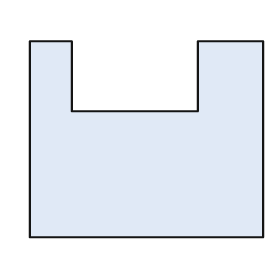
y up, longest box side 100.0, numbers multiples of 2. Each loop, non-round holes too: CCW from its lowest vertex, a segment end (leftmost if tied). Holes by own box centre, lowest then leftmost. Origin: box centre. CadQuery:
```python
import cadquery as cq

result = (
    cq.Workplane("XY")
    .moveTo(-50.0, -42.0)
    .lineTo(50.0, -42.0)
    .lineTo(50.0, 42.0)
    .lineTo(22.0, 42.0)
    .lineTo(22.0, 12.0)
    .lineTo(-32.0, 12.0)
    .lineTo(-32.0, 42.0)
    .lineTo(-50.0, 42.0)
    .close()
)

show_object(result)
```